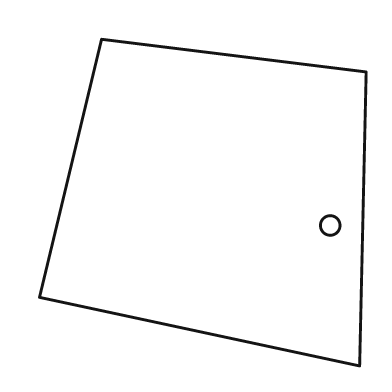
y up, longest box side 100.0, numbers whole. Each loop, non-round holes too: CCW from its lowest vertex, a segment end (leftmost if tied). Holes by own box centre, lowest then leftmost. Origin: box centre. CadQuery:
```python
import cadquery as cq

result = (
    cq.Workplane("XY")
    .moveTo(48.0, -50.0)
    .lineTo(50.0, 40.0)
    .lineTo(-31.0, 50.0)
    .lineTo(-50.0, -29.0)
    .close()
    .moveTo(39.0, -7.0)
    .circle(3.0)
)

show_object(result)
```